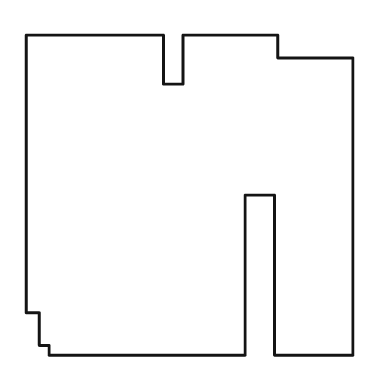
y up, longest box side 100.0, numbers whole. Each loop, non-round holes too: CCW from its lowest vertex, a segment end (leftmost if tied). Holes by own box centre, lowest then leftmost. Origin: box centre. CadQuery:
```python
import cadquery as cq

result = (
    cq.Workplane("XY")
    .moveTo(-43.0, -49.0)
    .lineTo(17.0, -49.0)
    .lineTo(17.0, 0.0)
    .lineTo(26.0, 0.0)
    .lineTo(26.0, -49.0)
    .lineTo(50.0, -49.0)
    .lineTo(50.0, 42.0)
    .lineTo(27.0, 42.0)
    .lineTo(27.0, 49.0)
    .lineTo(-2.0, 49.0)
    .lineTo(-2.0, 34.0)
    .lineTo(-8.0, 34.0)
    .lineTo(-8.0, 49.0)
    .lineTo(-50.0, 49.0)
    .lineTo(-50.0, -36.0)
    .lineTo(-46.0, -36.0)
    .lineTo(-46.0, -46.0)
    .lineTo(-43.0, -46.0)
    .close()
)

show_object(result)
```